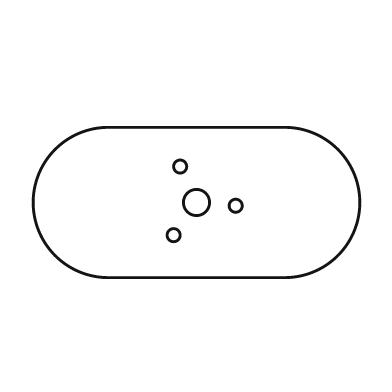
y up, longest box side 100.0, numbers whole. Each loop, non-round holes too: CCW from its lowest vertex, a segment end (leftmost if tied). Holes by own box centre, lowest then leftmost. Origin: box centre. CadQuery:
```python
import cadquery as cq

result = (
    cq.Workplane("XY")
    .moveTo(-27.0, -23.0)
    .lineTo(27.0, -23.0)
    .threePointArc((50.0, 0.0), (27.0, 23.0))
    .lineTo(-27.0, 23.0)
    .threePointArc((-50.0, 0.0), (-27.0, -23.0))
    .close()
    .moveTo(-7.0, -10.0)
    .circle(2.0)
    .moveTo(12.0, -1.0)
    .circle(2.0)
    .moveTo(0.0, 0.0)
    .circle(4.0)
    .moveTo(-5.0, 11.0)
    .circle(2.0)
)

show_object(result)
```